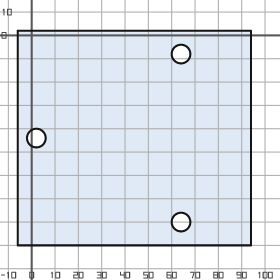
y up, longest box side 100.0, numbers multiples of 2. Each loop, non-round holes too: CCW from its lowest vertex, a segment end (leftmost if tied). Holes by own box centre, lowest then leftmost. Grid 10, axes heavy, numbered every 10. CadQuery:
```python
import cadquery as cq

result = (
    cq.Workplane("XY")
    .moveTo(-6.0, -90.0)
    .lineTo(94.0, -90.0)
    .lineTo(94.0, 2.0)
    .lineTo(-6.0, 2.0)
    .close()
    .moveTo(64.0, -80.0)
    .circle(4.0)
    .moveTo(2.0, -44.0)
    .circle(4.0)
    .moveTo(64.0, -8.0)
    .circle(4.0)
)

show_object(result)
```